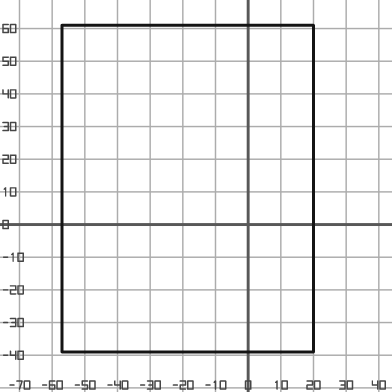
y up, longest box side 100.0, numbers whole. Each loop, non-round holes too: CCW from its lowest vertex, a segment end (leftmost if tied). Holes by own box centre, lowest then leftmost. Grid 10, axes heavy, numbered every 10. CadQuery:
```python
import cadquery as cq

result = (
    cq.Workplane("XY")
    .moveTo(-57.0, -39.0)
    .lineTo(20.0, -39.0)
    .lineTo(20.0, 61.0)
    .lineTo(-57.0, 61.0)
    .close()
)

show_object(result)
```